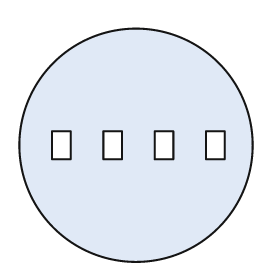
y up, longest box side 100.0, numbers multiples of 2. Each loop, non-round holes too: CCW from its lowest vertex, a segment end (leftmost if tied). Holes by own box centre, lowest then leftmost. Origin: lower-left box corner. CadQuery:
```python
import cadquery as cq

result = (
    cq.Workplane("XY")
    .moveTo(50.0, 50.0)
    .circle(50.0)
    .moveTo(14.0, 44.0)
    .lineTo(22.0, 44.0)
    .lineTo(22.0, 56.0)
    .lineTo(14.0, 56.0)
    .close()
    .moveTo(36.0, 44.0)
    .lineTo(44.0, 44.0)
    .lineTo(44.0, 56.0)
    .lineTo(36.0, 56.0)
    .close()
    .moveTo(58.0, 44.0)
    .lineTo(66.0, 44.0)
    .lineTo(66.0, 56.0)
    .lineTo(58.0, 56.0)
    .close()
    .moveTo(80.0, 44.0)
    .lineTo(88.0, 44.0)
    .lineTo(88.0, 56.0)
    .lineTo(80.0, 56.0)
    .close()
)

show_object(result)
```